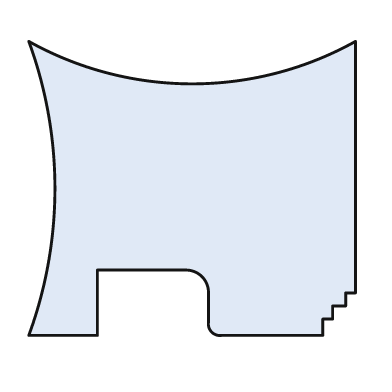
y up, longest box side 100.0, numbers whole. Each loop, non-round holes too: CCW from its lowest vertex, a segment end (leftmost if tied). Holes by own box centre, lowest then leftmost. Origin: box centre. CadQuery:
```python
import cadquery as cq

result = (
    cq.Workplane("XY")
    .moveTo(-50.0, -45.0)
    .lineTo(-29.0, -45.0)
    .lineTo(-29.0, -25.0)
    .lineTo(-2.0, -25.0)
    .threePointArc((3.0, -27.0), (5.0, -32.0))
    .lineTo(5.0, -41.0)
    .threePointArc((6.0, -44.0), (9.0, -45.0))
    .lineTo(40.0, -45.0)
    .lineTo(40.0, -40.0)
    .lineTo(43.0, -40.0)
    .lineTo(43.0, -36.0)
    .lineTo(47.0, -36.0)
    .lineTo(47.0, -32.0)
    .lineTo(50.0, -32.0)
    .lineTo(50.0, 45.0)
    .threePointArc((0.0, 32.0), (-50.0, 45.0))
    .threePointArc((-42.0, 0.0), (-50.0, -45.0))
    .close()
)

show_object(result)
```